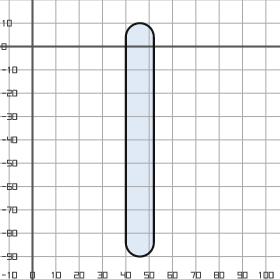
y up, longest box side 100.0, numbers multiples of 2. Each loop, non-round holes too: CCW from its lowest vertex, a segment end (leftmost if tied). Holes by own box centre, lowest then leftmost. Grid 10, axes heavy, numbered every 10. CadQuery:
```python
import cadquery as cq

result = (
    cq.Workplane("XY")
    .moveTo(40.0, -84.0)
    .threePointArc((46.0, -90.0), (52.0, -84.0))
    .lineTo(52.0, 4.0)
    .threePointArc((46.0, 10.0), (40.0, 4.0))
    .close()
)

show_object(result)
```